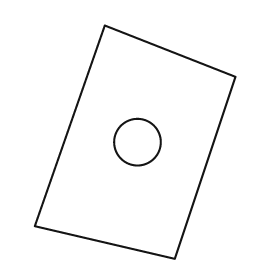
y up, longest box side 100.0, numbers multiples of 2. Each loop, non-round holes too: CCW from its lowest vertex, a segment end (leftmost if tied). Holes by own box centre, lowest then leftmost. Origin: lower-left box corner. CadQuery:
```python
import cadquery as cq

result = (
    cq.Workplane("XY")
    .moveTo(60.0, 0.0)
    .lineTo(86.0, 78.0)
    .lineTo(30.0, 100.0)
    .lineTo(0.0, 14.0)
    .close()
    .moveTo(44.0, 50.0)
    .circle(10.0)
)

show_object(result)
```